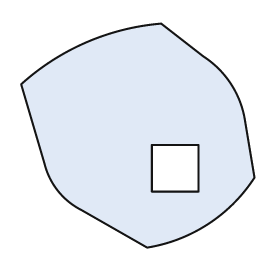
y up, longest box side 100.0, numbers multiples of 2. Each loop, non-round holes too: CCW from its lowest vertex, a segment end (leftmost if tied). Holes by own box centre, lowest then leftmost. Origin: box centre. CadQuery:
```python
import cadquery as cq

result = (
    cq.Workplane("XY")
    .moveTo(4.0, -48.0)
    .threePointArc((30.0, -38.0), (50.0, -18.0))
    .lineTo(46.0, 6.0)
    .threePointArc((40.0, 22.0), (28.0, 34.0))
    .lineTo(10.0, 48.0)
    .threePointArc((-22.0, 40.0), (-50.0, 22.0))
    .lineTo(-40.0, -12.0)
    .threePointArc((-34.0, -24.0), (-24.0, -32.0))
    .close()
    .moveTo(6.0, -24.0)
    .lineTo(26.0, -24.0)
    .lineTo(26.0, -4.0)
    .lineTo(6.0, -4.0)
    .close()
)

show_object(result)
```